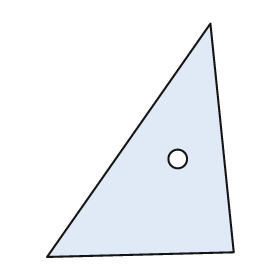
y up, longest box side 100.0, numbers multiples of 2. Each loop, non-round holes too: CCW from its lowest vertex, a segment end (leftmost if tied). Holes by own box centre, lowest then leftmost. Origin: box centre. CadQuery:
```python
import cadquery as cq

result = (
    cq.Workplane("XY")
    .moveTo(-40.0, -50.0)
    .lineTo(40.0, -48.0)
    .lineTo(30.0, 50.0)
    .close()
    .moveTo(16.0, -8.0)
    .circle(4.0)
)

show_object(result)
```